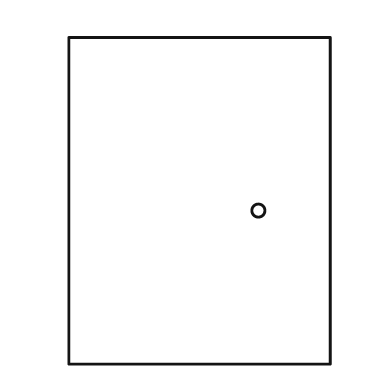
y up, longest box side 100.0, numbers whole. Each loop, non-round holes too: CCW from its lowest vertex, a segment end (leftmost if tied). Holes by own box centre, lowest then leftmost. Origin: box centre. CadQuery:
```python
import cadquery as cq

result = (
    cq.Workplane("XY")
    .moveTo(-40.0, -50.0)
    .lineTo(40.0, -50.0)
    .lineTo(40.0, 50.0)
    .lineTo(-40.0, 50.0)
    .close()
    .moveTo(18.0, -3.0)
    .circle(2.0)
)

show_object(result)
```